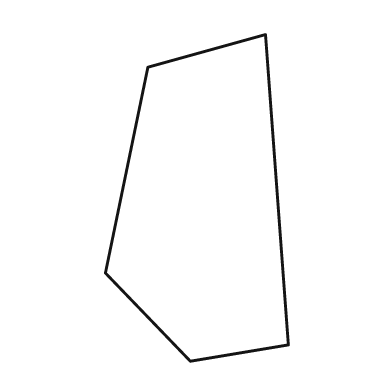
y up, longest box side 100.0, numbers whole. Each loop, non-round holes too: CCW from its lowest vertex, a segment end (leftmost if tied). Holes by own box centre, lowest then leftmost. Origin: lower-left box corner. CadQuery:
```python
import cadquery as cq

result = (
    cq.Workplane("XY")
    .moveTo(26.0, 0.0)
    .lineTo(56.0, 5.0)
    .lineTo(49.0, 100.0)
    .lineTo(13.0, 90.0)
    .lineTo(0.0, 27.0)
    .close()
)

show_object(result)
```